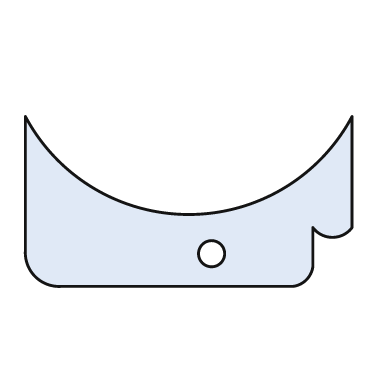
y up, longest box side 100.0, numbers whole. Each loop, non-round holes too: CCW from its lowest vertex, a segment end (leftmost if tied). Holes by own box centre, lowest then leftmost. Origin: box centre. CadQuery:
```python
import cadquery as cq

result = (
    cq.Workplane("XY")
    .moveTo(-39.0, -26.0)
    .lineTo(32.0, -26.0)
    .threePointArc((36.0, -24.0), (38.0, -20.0))
    .lineTo(38.0, -8.0)
    .threePointArc((44.0, -11.0), (50.0, -8.0))
    .lineTo(50.0, 26.0)
    .threePointArc((0.0, -4.0), (-50.0, 26.0))
    .lineTo(-50.0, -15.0)
    .threePointArc((-47.0, -23.0), (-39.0, -26.0))
    .close()
    .moveTo(7.0, -16.0)
    .circle(4.0)
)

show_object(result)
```